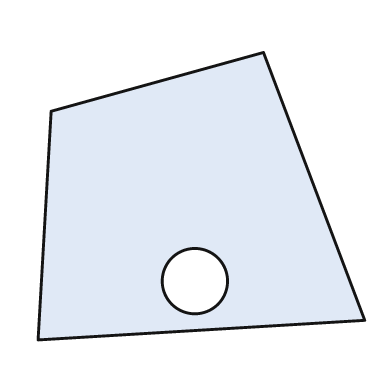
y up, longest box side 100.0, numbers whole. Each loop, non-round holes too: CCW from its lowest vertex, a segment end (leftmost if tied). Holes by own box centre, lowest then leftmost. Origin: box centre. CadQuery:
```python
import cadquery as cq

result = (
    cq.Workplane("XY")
    .moveTo(-50.0, -44.0)
    .lineTo(50.0, -38.0)
    .lineTo(19.0, 44.0)
    .lineTo(-46.0, 26.0)
    .close()
    .moveTo(-2.0, -26.0)
    .circle(10.0)
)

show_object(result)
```